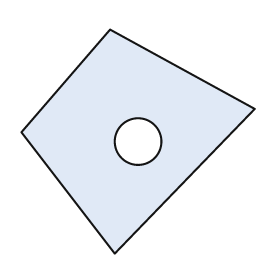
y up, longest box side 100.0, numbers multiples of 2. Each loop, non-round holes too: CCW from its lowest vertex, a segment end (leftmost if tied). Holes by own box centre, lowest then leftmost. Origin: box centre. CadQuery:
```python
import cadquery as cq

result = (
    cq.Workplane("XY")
    .moveTo(-10.0, -48.0)
    .lineTo(50.0, 14.0)
    .lineTo(-12.0, 48.0)
    .lineTo(-50.0, 4.0)
    .close()
    .moveTo(0.0, 0.0)
    .circle(10.0)
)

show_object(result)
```